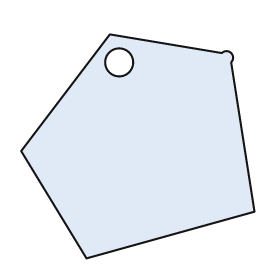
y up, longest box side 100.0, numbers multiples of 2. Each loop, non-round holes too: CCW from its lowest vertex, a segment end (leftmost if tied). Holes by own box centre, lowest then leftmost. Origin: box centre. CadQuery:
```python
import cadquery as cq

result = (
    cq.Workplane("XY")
    .moveTo(-22.0, -48.0)
    .lineTo(50.0, -28.0)
    .lineTo(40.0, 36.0)
    .threePointArc((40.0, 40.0), (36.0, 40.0))
    .lineTo(-12.0, 48.0)
    .lineTo(-50.0, -2.0)
    .close()
    .moveTo(-8.0, 36.0)
    .circle(6.0)
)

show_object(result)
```